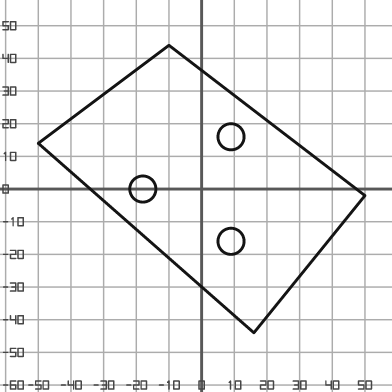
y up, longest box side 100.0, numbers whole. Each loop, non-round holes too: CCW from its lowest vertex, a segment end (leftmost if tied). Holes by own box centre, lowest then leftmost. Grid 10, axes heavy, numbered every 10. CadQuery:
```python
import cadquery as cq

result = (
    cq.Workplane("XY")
    .moveTo(16.0, -44.0)
    .lineTo(50.0, -2.0)
    .lineTo(-10.0, 44.0)
    .lineTo(-50.0, 14.0)
    .close()
    .moveTo(9.0, -16.0)
    .circle(4.0)
    .moveTo(-18.0, 0.0)
    .circle(4.0)
    .moveTo(9.0, 16.0)
    .circle(4.0)
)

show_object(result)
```